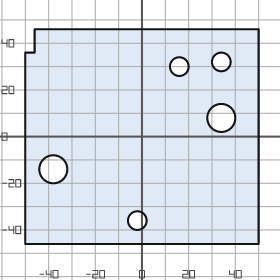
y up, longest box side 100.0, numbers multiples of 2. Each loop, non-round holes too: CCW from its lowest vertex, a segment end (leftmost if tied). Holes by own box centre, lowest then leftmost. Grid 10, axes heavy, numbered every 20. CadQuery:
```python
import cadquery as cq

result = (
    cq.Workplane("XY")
    .moveTo(-50.0, -46.0)
    .lineTo(50.0, -46.0)
    .lineTo(50.0, 46.0)
    .lineTo(-46.0, 46.0)
    .lineTo(-46.0, 36.0)
    .lineTo(-50.0, 36.0)
    .close()
    .moveTo(-2.0, -36.0)
    .circle(4.0)
    .moveTo(-38.0, -14.0)
    .circle(6.0)
    .moveTo(34.0, 8.0)
    .circle(6.0)
    .moveTo(16.0, 30.0)
    .circle(4.0)
    .moveTo(34.0, 32.0)
    .circle(4.0)
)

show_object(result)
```